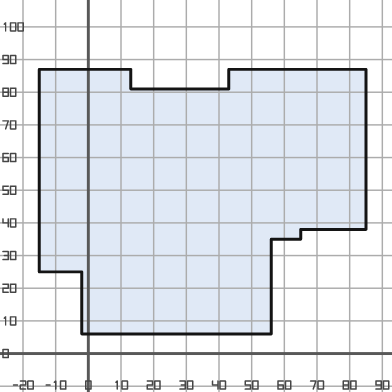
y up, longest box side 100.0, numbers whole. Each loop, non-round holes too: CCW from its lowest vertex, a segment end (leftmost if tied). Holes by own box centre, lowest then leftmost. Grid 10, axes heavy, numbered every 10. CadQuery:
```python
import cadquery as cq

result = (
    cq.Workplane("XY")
    .moveTo(-2.0, 6.0)
    .lineTo(56.0, 6.0)
    .lineTo(56.0, 35.0)
    .lineTo(65.0, 35.0)
    .lineTo(65.0, 38.0)
    .lineTo(85.0, 38.0)
    .lineTo(85.0, 87.0)
    .lineTo(43.0, 87.0)
    .lineTo(43.0, 81.0)
    .lineTo(13.0, 81.0)
    .lineTo(13.0, 87.0)
    .lineTo(-15.0, 87.0)
    .lineTo(-15.0, 25.0)
    .lineTo(-2.0, 25.0)
    .close()
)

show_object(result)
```